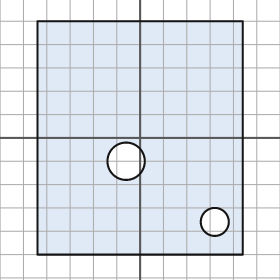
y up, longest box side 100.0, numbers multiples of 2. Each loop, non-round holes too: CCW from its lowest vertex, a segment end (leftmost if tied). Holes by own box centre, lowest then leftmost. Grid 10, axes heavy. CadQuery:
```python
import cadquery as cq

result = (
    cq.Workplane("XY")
    .moveTo(-44.0, -50.0)
    .lineTo(44.0, -50.0)
    .lineTo(44.0, 50.0)
    .lineTo(-44.0, 50.0)
    .close()
    .moveTo(32.0, -36.0)
    .circle(6.0)
    .moveTo(-6.0, -10.0)
    .circle(8.0)
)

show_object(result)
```